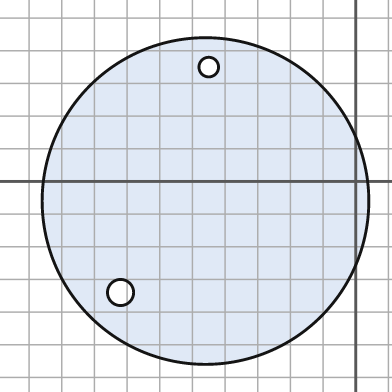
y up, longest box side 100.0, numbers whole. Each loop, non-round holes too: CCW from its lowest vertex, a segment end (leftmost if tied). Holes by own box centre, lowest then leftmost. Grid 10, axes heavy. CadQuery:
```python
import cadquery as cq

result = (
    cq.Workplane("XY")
    .moveTo(-46.0, -6.0)
    .circle(50.0)
    .moveTo(-72.0, -34.0)
    .circle(4.0)
    .moveTo(-45.0, 35.0)
    .circle(3.0)
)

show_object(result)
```